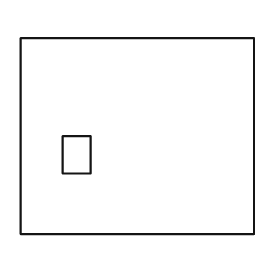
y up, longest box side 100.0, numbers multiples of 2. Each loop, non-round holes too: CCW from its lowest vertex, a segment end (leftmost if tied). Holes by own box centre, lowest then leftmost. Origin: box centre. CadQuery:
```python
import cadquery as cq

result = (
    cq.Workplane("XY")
    .moveTo(-50.0, -42.0)
    .lineTo(50.0, -42.0)
    .lineTo(50.0, 42.0)
    .lineTo(-50.0, 42.0)
    .close()
    .moveTo(-32.0, -16.0)
    .lineTo(-20.0, -16.0)
    .lineTo(-20.0, 0.0)
    .lineTo(-32.0, 0.0)
    .close()
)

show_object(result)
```